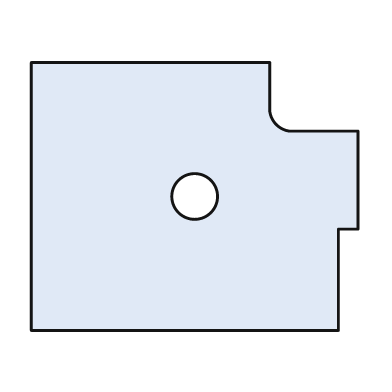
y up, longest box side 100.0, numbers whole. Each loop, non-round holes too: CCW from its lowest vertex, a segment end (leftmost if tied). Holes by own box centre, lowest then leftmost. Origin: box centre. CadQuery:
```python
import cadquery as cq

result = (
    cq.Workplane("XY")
    .moveTo(-50.0, -41.0)
    .lineTo(44.0, -41.0)
    .lineTo(44.0, -10.0)
    .lineTo(50.0, -10.0)
    .lineTo(50.0, 20.0)
    .lineTo(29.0, 20.0)
    .threePointArc((25.0, 22.0), (23.0, 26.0))
    .lineTo(23.0, 41.0)
    .lineTo(-50.0, 41.0)
    .close()
    .moveTo(0.0, 0.0)
    .circle(7.0)
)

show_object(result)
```